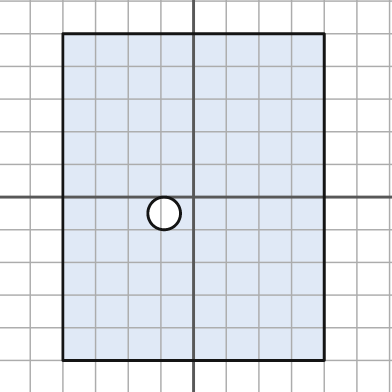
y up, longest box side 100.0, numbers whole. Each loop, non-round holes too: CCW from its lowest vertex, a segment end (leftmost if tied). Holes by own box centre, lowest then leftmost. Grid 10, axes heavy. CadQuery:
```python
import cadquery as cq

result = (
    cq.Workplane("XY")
    .moveTo(-40.0, -50.0)
    .lineTo(40.0, -50.0)
    .lineTo(40.0, 50.0)
    .lineTo(-40.0, 50.0)
    .close()
    .moveTo(-9.0, -5.0)
    .circle(5.0)
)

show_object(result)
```